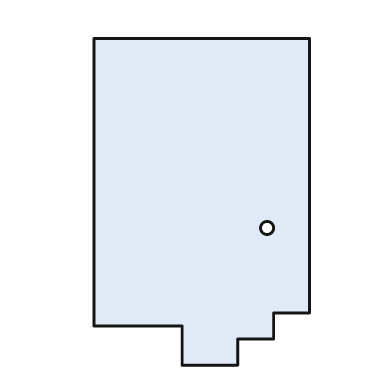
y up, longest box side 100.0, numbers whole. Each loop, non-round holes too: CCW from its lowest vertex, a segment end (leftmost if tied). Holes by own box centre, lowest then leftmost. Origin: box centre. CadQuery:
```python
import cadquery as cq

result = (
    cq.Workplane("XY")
    .moveTo(-6.0, -50.0)
    .lineTo(11.0, -50.0)
    .lineTo(11.0, -42.0)
    .lineTo(22.0, -42.0)
    .lineTo(22.0, -34.0)
    .lineTo(33.0, -34.0)
    .lineTo(33.0, 50.0)
    .lineTo(-33.0, 50.0)
    .lineTo(-33.0, -38.0)
    .lineTo(-6.0, -38.0)
    .close()
    .moveTo(20.0, -8.0)
    .circle(2.0)
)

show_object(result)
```